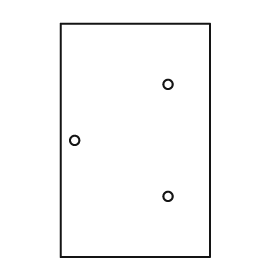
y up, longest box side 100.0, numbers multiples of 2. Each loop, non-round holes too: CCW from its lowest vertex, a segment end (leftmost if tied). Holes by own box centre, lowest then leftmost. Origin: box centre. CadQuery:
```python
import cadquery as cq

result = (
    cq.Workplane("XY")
    .moveTo(-32.0, -50.0)
    .lineTo(32.0, -50.0)
    .lineTo(32.0, 50.0)
    .lineTo(-32.0, 50.0)
    .close()
    .moveTo(14.0, -24.0)
    .circle(2.0)
    .moveTo(-26.0, 0.0)
    .circle(2.0)
    .moveTo(14.0, 24.0)
    .circle(2.0)
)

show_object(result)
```